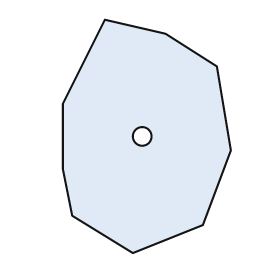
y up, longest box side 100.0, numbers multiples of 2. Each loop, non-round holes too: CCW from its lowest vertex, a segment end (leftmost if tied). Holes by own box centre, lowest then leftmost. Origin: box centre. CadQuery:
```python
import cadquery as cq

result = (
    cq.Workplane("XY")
    .moveTo(-6.0, -50.0)
    .lineTo(24.0, -38.0)
    .lineTo(36.0, -6.0)
    .lineTo(30.0, 30.0)
    .lineTo(8.0, 44.0)
    .lineTo(-18.0, 50.0)
    .lineTo(-36.0, 14.0)
    .lineTo(-36.0, -14.0)
    .lineTo(-32.0, -34.0)
    .close()
    .moveTo(-2.0, 0.0)
    .circle(4.0)
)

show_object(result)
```